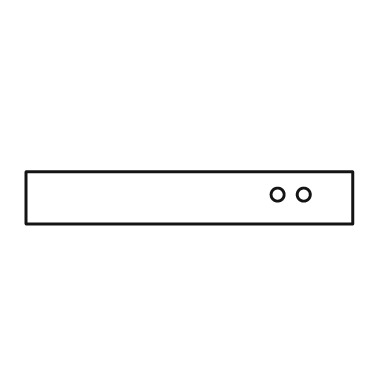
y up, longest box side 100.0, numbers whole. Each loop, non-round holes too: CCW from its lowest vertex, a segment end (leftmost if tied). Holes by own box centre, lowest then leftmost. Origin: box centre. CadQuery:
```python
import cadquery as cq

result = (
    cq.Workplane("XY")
    .moveTo(-50.0, -8.0)
    .lineTo(50.0, -8.0)
    .lineTo(50.0, 8.0)
    .lineTo(-50.0, 8.0)
    .close()
    .moveTo(27.0, 1.0)
    .circle(2.0)
    .moveTo(35.0, 1.0)
    .circle(2.0)
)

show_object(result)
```